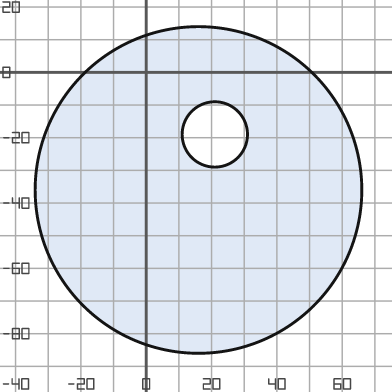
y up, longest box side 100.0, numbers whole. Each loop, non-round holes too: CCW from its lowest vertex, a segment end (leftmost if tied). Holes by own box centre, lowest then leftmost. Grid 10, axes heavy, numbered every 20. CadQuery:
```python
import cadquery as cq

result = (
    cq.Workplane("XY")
    .moveTo(16.0, -36.0)
    .circle(50.0)
    .moveTo(21.0, -19.0)
    .circle(10.0)
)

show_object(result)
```